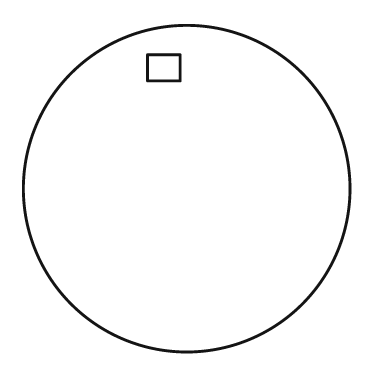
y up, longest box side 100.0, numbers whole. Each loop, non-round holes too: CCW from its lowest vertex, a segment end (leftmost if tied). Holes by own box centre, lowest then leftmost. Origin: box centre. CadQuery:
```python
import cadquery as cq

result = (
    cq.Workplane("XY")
    .moveTo(0.0, 0.0)
    .circle(50.0)
    .moveTo(-12.0, 33.0)
    .lineTo(-2.0, 33.0)
    .lineTo(-2.0, 41.0)
    .lineTo(-12.0, 41.0)
    .close()
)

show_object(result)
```